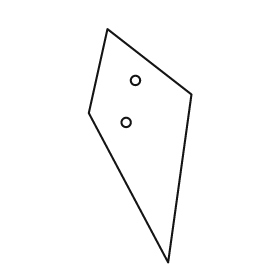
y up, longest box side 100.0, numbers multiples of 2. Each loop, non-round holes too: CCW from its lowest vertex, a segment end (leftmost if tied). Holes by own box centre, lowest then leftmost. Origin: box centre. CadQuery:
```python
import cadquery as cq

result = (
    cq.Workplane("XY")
    .moveTo(12.0, -50.0)
    .lineTo(22.0, 22.0)
    .lineTo(-14.0, 50.0)
    .lineTo(-22.0, 14.0)
    .close()
    .moveTo(-6.0, 10.0)
    .circle(2.0)
    .moveTo(-2.0, 28.0)
    .circle(2.0)
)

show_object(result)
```